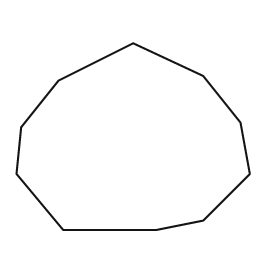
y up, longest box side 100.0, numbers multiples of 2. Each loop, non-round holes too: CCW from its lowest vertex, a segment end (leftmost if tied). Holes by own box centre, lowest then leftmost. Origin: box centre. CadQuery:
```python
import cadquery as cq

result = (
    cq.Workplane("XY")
    .moveTo(-30.0, -40.0)
    .lineTo(10.0, -40.0)
    .lineTo(30.0, -36.0)
    .lineTo(50.0, -16.0)
    .lineTo(46.0, 6.0)
    .lineTo(30.0, 26.0)
    .lineTo(0.0, 40.0)
    .lineTo(-32.0, 24.0)
    .lineTo(-48.0, 4.0)
    .lineTo(-50.0, -16.0)
    .close()
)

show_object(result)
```